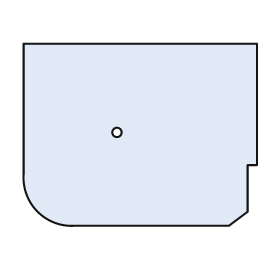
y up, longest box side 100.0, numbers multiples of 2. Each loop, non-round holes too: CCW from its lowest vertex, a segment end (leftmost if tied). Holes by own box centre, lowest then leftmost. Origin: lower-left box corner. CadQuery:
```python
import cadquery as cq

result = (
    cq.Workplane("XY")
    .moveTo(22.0, 0.0)
    .lineTo(88.0, 0.0)
    .lineTo(96.0, 6.0)
    .lineTo(96.0, 26.0)
    .lineTo(100.0, 26.0)
    .lineTo(100.0, 78.0)
    .lineTo(0.0, 78.0)
    .lineTo(0.0, 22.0)
    .threePointArc((6.0, 6.0), (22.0, 0.0))
    .close()
    .moveTo(40.0, 40.0)
    .circle(2.0)
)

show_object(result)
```